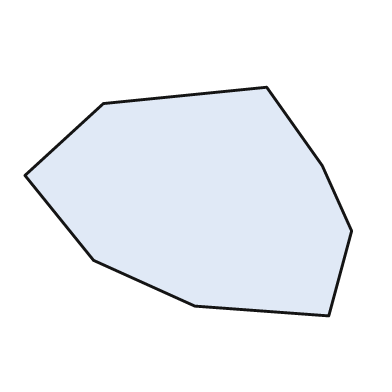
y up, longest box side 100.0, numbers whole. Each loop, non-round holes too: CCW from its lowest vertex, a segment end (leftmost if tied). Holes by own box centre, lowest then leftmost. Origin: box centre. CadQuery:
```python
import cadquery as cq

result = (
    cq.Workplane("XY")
    .moveTo(43.0, -35.0)
    .lineTo(50.0, -9.0)
    .lineTo(41.0, 11.0)
    .lineTo(24.0, 35.0)
    .lineTo(-26.0, 30.0)
    .lineTo(-50.0, 8.0)
    .lineTo(-29.0, -18.0)
    .lineTo(2.0, -32.0)
    .close()
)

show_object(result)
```